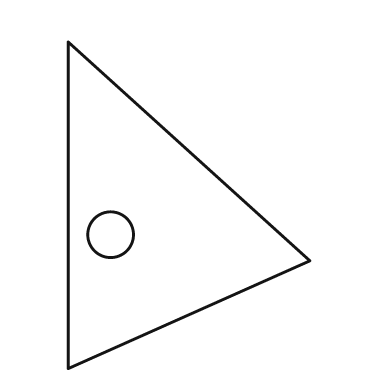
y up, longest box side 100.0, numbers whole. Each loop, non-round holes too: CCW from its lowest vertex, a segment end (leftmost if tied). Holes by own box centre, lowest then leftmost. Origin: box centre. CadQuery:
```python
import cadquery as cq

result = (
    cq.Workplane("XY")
    .moveTo(-37.0, -50.0)
    .lineTo(37.0, -17.0)
    .lineTo(-37.0, 50.0)
    .close()
    .moveTo(-24.0, -9.0)
    .circle(7.0)
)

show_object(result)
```